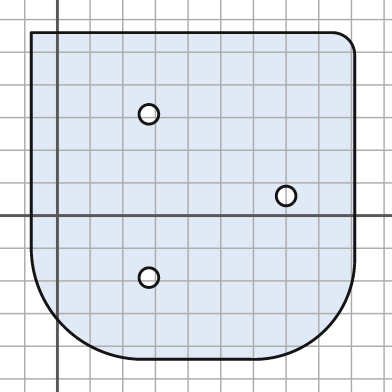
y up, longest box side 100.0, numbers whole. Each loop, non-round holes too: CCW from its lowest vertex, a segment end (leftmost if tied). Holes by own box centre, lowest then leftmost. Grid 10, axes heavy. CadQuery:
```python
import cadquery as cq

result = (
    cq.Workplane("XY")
    .moveTo(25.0, -44.0)
    .lineTo(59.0, -44.0)
    .threePointArc((82.0, -35.0), (91.0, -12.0))
    .lineTo(91.0, 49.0)
    .threePointArc((89.0, 54.0), (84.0, 56.0))
    .lineTo(-8.0, 56.0)
    .lineTo(-8.0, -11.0)
    .threePointArc((2.0, -34.0), (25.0, -44.0))
    .close()
    .moveTo(28.0, -19.0)
    .circle(3.0)
    .moveTo(70.0, 6.0)
    .circle(3.0)
    .moveTo(28.0, 31.0)
    .circle(3.0)
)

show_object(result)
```